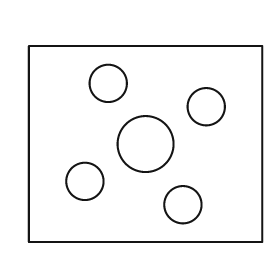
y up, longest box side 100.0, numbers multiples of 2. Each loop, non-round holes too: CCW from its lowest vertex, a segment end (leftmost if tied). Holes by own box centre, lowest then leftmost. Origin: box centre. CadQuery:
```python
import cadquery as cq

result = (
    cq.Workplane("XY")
    .moveTo(-50.0, -42.0)
    .lineTo(50.0, -42.0)
    .lineTo(50.0, 42.0)
    .lineTo(-50.0, 42.0)
    .close()
    .moveTo(16.0, -26.0)
    .circle(8.0)
    .moveTo(-26.0, -16.0)
    .circle(8.0)
    .moveTo(0.0, 0.0)
    .circle(12.0)
    .moveTo(26.0, 16.0)
    .circle(8.0)
    .moveTo(-16.0, 26.0)
    .circle(8.0)
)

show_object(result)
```